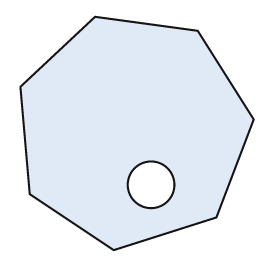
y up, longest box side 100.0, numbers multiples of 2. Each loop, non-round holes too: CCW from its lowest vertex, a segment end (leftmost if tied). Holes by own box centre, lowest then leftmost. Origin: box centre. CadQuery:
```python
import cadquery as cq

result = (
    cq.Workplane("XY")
    .moveTo(-10.0, -50.0)
    .lineTo(34.0, -36.0)
    .lineTo(50.0, 6.0)
    .lineTo(26.0, 44.0)
    .lineTo(-18.0, 50.0)
    .lineTo(-50.0, 20.0)
    .lineTo(-46.0, -26.0)
    .close()
    .moveTo(6.0, -22.0)
    .circle(10.0)
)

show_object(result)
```